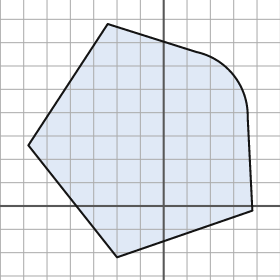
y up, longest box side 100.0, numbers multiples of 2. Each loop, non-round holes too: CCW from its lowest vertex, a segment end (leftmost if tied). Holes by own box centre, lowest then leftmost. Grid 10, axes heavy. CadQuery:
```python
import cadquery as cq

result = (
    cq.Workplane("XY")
    .moveTo(-20.0, -22.0)
    .lineTo(38.0, -2.0)
    .lineTo(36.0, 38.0)
    .threePointArc((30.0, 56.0), (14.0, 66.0))
    .lineTo(-24.0, 78.0)
    .lineTo(-58.0, 26.0)
    .close()
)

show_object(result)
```